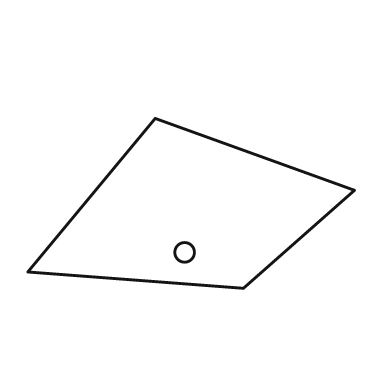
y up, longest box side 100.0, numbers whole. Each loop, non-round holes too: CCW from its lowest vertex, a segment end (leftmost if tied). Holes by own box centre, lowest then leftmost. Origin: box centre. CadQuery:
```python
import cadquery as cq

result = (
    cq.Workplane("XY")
    .moveTo(16.0, -26.0)
    .lineTo(50.0, 4.0)
    .lineTo(-11.0, 26.0)
    .lineTo(-50.0, -21.0)
    .close()
    .moveTo(-2.0, -15.0)
    .circle(3.0)
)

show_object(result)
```